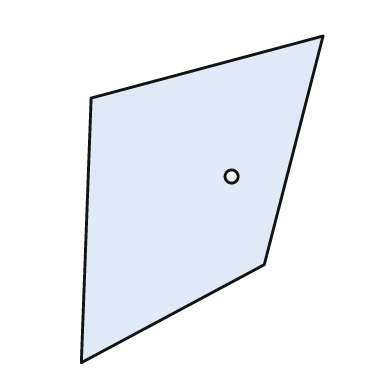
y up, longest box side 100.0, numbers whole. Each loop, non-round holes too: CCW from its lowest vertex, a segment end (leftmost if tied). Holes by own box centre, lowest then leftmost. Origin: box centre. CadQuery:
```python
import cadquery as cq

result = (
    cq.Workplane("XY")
    .moveTo(-37.0, -50.0)
    .lineTo(19.0, -20.0)
    .lineTo(37.0, 50.0)
    .lineTo(-34.0, 31.0)
    .close()
    .moveTo(9.0, 7.0)
    .circle(2.0)
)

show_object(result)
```